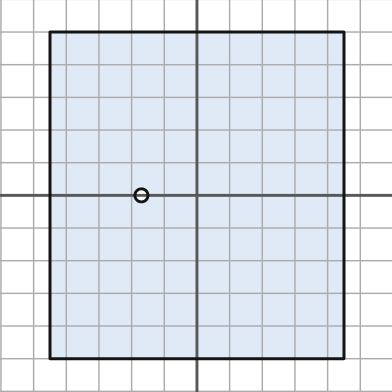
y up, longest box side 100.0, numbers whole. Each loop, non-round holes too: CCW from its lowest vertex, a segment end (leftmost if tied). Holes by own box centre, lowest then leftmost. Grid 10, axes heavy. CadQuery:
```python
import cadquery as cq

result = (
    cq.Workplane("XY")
    .moveTo(-45.0, -50.0)
    .lineTo(45.0, -50.0)
    .lineTo(45.0, 50.0)
    .lineTo(-45.0, 50.0)
    .close()
    .moveTo(-17.0, 0.0)
    .circle(2.0)
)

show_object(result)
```